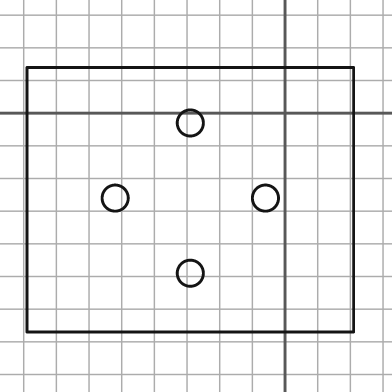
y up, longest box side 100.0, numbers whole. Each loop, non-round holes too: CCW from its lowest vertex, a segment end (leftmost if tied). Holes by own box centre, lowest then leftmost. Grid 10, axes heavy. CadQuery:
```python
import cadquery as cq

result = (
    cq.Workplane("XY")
    .moveTo(-79.0, -67.0)
    .lineTo(21.0, -67.0)
    .lineTo(21.0, 14.0)
    .lineTo(-79.0, 14.0)
    .close()
    .moveTo(-29.0, -49.0)
    .circle(4.0)
    .moveTo(-52.0, -26.0)
    .circle(4.0)
    .moveTo(-6.0, -26.0)
    .circle(4.0)
    .moveTo(-29.0, -3.0)
    .circle(4.0)
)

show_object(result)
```